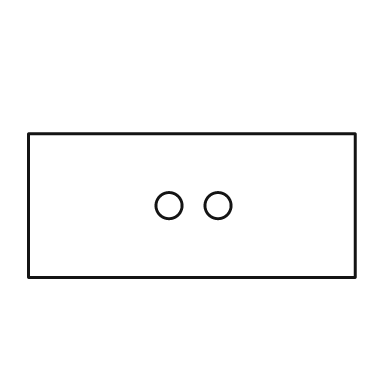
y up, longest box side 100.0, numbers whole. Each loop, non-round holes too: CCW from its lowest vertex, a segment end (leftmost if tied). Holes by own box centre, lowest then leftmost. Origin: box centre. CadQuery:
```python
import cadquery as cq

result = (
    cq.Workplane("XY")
    .moveTo(-50.0, -22.0)
    .lineTo(50.0, -22.0)
    .lineTo(50.0, 22.0)
    .lineTo(-50.0, 22.0)
    .close()
    .moveTo(-7.0, 0.0)
    .circle(4.0)
    .moveTo(8.0, 0.0)
    .circle(4.0)
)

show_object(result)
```